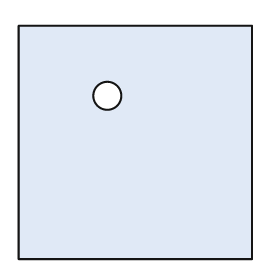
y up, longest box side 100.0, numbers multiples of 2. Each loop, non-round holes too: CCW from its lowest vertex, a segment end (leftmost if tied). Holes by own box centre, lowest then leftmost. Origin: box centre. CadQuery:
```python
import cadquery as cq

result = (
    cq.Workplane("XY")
    .moveTo(-50.0, -50.0)
    .lineTo(50.0, -50.0)
    .lineTo(50.0, 50.0)
    .lineTo(-50.0, 50.0)
    .close()
    .moveTo(-12.0, 20.0)
    .circle(6.0)
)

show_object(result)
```